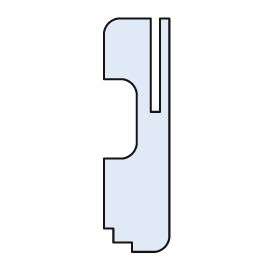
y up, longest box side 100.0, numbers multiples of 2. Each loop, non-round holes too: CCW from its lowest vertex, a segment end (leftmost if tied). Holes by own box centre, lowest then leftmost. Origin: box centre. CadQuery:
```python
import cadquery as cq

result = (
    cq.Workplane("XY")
    .moveTo(-2.0, -50.0)
    .lineTo(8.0, -50.0)
    .threePointArc((12.0, -48.0), (14.0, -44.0))
    .lineTo(14.0, 50.0)
    .lineTo(10.0, 50.0)
    .lineTo(10.0, 10.0)
    .lineTo(6.0, 10.0)
    .lineTo(6.0, 50.0)
    .lineTo(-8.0, 50.0)
    .threePointArc((-12.0, 48.0), (-14.0, 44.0))
    .lineTo(-14.0, 24.0)
    .lineTo(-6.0, 24.0)
    .threePointArc((-2.0, 22.0), (0.0, 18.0))
    .lineTo(0.0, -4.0)
    .threePointArc((-2.0, -8.0), (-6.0, -10.0))
    .lineTo(-14.0, -10.0)
    .lineTo(-14.0, -40.0)
    .lineTo(-10.0, -40.0)
    .lineTo(-10.0, -46.0)
    .lineTo(-2.0, -46.0)
    .close()
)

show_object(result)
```